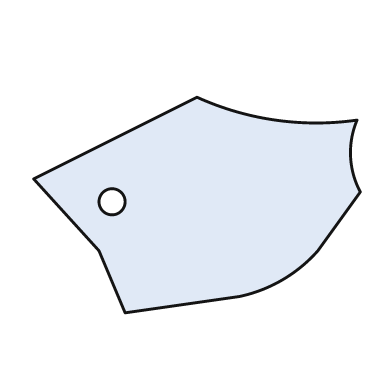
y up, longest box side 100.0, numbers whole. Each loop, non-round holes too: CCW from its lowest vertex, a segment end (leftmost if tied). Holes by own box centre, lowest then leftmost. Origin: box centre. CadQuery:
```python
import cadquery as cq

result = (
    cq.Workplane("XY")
    .moveTo(-22.0, -33.0)
    .lineTo(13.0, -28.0)
    .threePointArc((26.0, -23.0), (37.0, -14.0))
    .lineTo(50.0, 4.0)
    .threePointArc((47.0, 15.0), (49.0, 26.0))
    .threePointArc((24.0, 26.0), (0.0, 33.0))
    .lineTo(-50.0, 8.0)
    .lineTo(-30.0, -14.0)
    .close()
    .moveTo(-26.0, 1.0)
    .circle(4.0)
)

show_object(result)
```